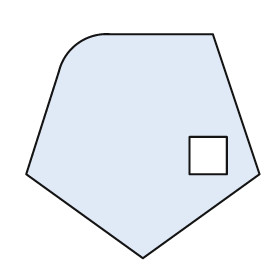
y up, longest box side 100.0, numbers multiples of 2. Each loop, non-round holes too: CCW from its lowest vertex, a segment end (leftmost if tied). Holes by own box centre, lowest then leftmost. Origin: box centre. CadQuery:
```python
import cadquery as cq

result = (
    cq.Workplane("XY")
    .moveTo(0.0, -48.0)
    .lineTo(50.0, -12.0)
    .lineTo(30.0, 48.0)
    .lineTo(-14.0, 48.0)
    .threePointArc((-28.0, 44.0), (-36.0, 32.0))
    .lineTo(-50.0, -12.0)
    .close()
    .moveTo(20.0, -12.0)
    .lineTo(36.0, -12.0)
    .lineTo(36.0, 4.0)
    .lineTo(20.0, 4.0)
    .close()
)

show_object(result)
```